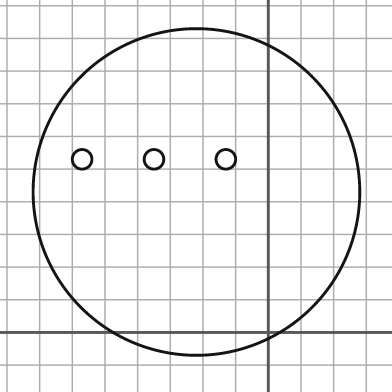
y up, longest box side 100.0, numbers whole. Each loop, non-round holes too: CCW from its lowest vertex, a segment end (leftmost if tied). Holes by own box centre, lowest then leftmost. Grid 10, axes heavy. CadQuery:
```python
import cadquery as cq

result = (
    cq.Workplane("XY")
    .moveTo(-22.0, 43.0)
    .circle(50.0)
    .moveTo(-57.0, 53.0)
    .circle(3.0)
    .moveTo(-35.0, 53.0)
    .circle(3.0)
    .moveTo(-13.0, 53.0)
    .circle(3.0)
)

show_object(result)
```